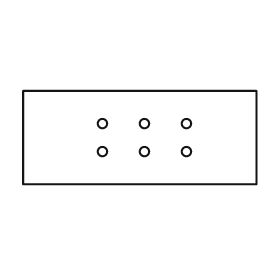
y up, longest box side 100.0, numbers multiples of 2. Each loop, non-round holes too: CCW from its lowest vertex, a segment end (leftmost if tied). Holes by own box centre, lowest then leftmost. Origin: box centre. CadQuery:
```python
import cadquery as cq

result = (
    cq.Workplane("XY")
    .moveTo(-50.0, -20.0)
    .lineTo(50.0, -20.0)
    .lineTo(50.0, 20.0)
    .lineTo(-50.0, 20.0)
    .close()
    .moveTo(-16.0, -6.0)
    .circle(2.0)
    .moveTo(2.0, -6.0)
    .circle(2.0)
    .moveTo(20.0, -6.0)
    .circle(2.0)
    .moveTo(-16.0, 6.0)
    .circle(2.0)
    .moveTo(2.0, 6.0)
    .circle(2.0)
    .moveTo(20.0, 6.0)
    .circle(2.0)
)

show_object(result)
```